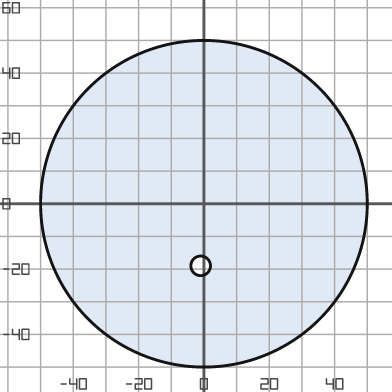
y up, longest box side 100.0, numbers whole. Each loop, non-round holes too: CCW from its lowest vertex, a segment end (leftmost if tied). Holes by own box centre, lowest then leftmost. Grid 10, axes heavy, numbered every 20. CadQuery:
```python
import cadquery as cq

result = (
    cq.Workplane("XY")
    .moveTo(0.0, 0.0)
    .circle(50.0)
    .moveTo(-1.0, -19.0)
    .circle(3.0)
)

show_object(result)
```